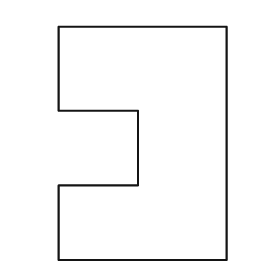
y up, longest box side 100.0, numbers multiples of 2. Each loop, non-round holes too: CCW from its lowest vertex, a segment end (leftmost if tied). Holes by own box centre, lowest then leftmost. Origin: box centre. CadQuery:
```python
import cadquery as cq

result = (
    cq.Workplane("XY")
    .moveTo(-36.0, -50.0)
    .lineTo(36.0, -50.0)
    .lineTo(36.0, 50.0)
    .lineTo(-36.0, 50.0)
    .lineTo(-36.0, 14.0)
    .lineTo(-2.0, 14.0)
    .lineTo(-2.0, -18.0)
    .lineTo(-36.0, -18.0)
    .close()
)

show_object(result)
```